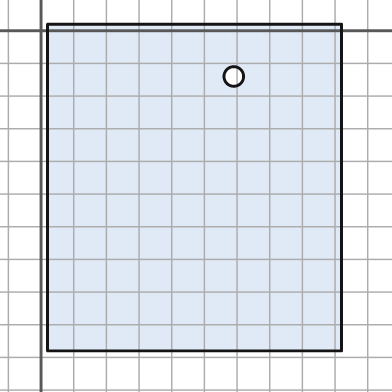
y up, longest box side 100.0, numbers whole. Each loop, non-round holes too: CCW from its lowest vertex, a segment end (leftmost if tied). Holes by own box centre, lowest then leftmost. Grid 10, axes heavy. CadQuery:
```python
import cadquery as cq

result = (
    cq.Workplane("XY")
    .moveTo(2.0, -98.0)
    .lineTo(92.0, -98.0)
    .lineTo(92.0, 2.0)
    .lineTo(2.0, 2.0)
    .close()
    .moveTo(59.0, -14.0)
    .circle(3.0)
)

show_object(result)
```